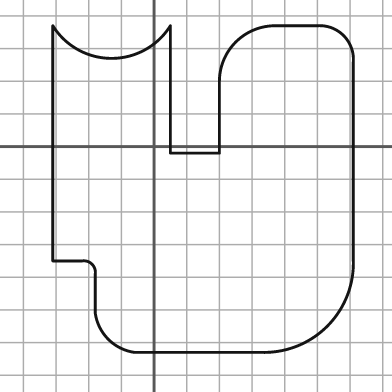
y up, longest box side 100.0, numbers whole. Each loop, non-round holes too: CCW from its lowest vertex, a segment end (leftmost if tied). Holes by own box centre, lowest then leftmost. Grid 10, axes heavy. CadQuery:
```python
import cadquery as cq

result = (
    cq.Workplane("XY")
    .moveTo(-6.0, -63.0)
    .lineTo(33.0, -63.0)
    .threePointArc((53.0, -55.0), (61.0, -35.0))
    .lineTo(61.0, 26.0)
    .threePointArc((58.0, 34.0), (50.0, 37.0))
    .lineTo(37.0, 37.0)
    .threePointArc((25.0, 32.0), (20.0, 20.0))
    .lineTo(20.0, -2.0)
    .lineTo(5.0, -2.0)
    .lineTo(5.0, 37.0)
    .threePointArc((-13.0, 27.0), (-31.0, 37.0))
    .lineTo(-31.0, -35.0)
    .lineTo(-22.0, -35.0)
    .threePointArc((-19.0, -36.0), (-18.0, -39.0))
    .lineTo(-18.0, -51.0)
    .threePointArc((-14.0, -59.0), (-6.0, -63.0))
    .close()
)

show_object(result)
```